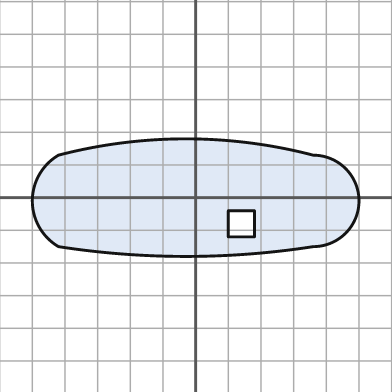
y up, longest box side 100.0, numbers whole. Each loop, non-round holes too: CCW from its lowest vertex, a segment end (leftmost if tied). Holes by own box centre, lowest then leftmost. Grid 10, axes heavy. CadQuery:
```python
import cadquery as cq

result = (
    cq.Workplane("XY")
    .moveTo(-42.0, -15.0)
    .threePointArc((-3.0, -18.0), (36.0, -15.0))
    .threePointArc((50.0, -1.0), (36.0, 13.0))
    .threePointArc((-3.0, 18.0), (-42.0, 13.0))
    .threePointArc((-50.0, -1.0), (-42.0, -15.0))
    .close()
    .moveTo(10.0, -12.0)
    .lineTo(18.0, -12.0)
    .lineTo(18.0, -4.0)
    .lineTo(10.0, -4.0)
    .close()
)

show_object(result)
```